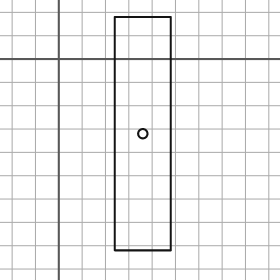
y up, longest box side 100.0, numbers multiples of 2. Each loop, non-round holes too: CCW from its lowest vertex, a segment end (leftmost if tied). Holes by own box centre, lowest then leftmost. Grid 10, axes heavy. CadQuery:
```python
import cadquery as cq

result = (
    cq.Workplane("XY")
    .moveTo(24.0, -82.0)
    .lineTo(48.0, -82.0)
    .lineTo(48.0, 18.0)
    .lineTo(24.0, 18.0)
    .close()
    .moveTo(36.0, -32.0)
    .circle(2.0)
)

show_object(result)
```